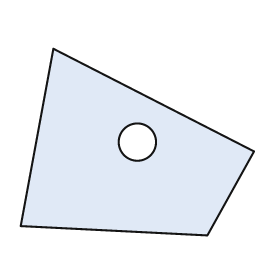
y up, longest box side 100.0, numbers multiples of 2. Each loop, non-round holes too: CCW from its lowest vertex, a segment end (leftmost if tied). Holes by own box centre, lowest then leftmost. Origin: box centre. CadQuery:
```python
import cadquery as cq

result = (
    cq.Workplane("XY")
    .moveTo(30.0, -40.0)
    .lineTo(50.0, -4.0)
    .lineTo(-36.0, 40.0)
    .lineTo(-50.0, -36.0)
    .close()
    .moveTo(0.0, 0.0)
    .circle(8.0)
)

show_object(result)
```